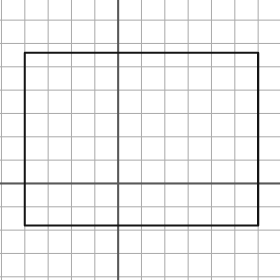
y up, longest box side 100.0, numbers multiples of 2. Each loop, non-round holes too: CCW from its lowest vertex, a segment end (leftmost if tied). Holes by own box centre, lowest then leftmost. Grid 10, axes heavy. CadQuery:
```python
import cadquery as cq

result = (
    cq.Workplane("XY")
    .moveTo(-40.0, -18.0)
    .lineTo(60.0, -18.0)
    .lineTo(60.0, 56.0)
    .lineTo(-40.0, 56.0)
    .close()
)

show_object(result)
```